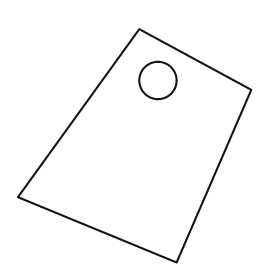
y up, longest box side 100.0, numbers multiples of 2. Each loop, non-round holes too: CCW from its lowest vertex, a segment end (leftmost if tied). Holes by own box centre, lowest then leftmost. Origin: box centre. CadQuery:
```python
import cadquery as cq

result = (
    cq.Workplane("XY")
    .moveTo(18.0, -50.0)
    .lineTo(50.0, 24.0)
    .lineTo(2.0, 50.0)
    .lineTo(-50.0, -22.0)
    .close()
    .moveTo(10.0, 28.0)
    .circle(8.0)
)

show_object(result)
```